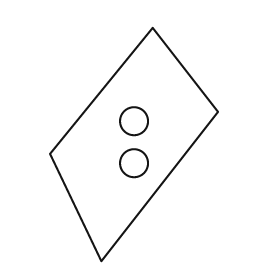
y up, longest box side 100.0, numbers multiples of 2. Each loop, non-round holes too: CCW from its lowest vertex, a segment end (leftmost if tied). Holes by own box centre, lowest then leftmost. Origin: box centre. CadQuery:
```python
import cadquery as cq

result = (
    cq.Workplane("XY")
    .moveTo(-14.0, -50.0)
    .lineTo(36.0, 14.0)
    .lineTo(8.0, 50.0)
    .lineTo(-36.0, -4.0)
    .close()
    .moveTo(0.0, -8.0)
    .circle(6.0)
    .moveTo(0.0, 10.0)
    .circle(6.0)
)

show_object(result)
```